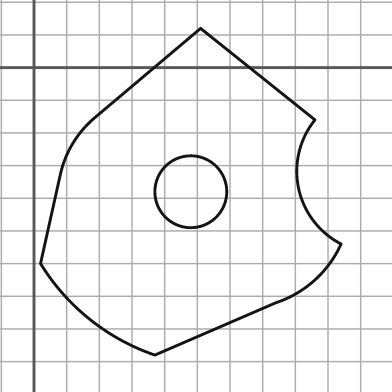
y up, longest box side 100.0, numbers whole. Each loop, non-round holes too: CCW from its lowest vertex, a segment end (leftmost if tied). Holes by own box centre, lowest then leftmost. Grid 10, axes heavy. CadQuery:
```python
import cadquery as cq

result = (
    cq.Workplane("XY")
    .moveTo(37.0, -88.0)
    .lineTo(74.0, -72.0)
    .threePointArc((86.0, -65.0), (94.0, -54.0))
    .threePointArc((81.0, -37.0), (86.0, -16.0))
    .lineTo(51.0, 12.0)
    .lineTo(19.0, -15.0)
    .threePointArc((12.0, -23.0), (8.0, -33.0))
    .lineTo(2.0, -60.0)
    .threePointArc((17.0, -77.0), (37.0, -88.0))
    .close()
    .moveTo(48.0, -38.0)
    .circle(11.0)
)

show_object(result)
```